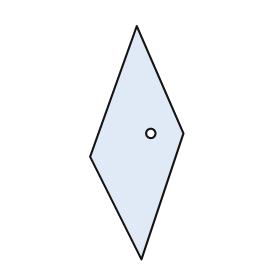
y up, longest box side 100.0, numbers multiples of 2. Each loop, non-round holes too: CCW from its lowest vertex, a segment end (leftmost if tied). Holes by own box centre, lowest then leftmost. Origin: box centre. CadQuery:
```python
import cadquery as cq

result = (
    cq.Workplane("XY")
    .moveTo(2.0, -50.0)
    .lineTo(20.0, 4.0)
    .lineTo(0.0, 50.0)
    .lineTo(-20.0, -6.0)
    .close()
    .moveTo(6.0, 4.0)
    .circle(2.0)
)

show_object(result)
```